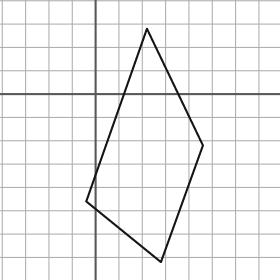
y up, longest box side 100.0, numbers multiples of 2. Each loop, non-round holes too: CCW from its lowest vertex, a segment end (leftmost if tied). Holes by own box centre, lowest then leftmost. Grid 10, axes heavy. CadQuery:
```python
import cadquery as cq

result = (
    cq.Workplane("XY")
    .moveTo(28.0, -72.0)
    .lineTo(46.0, -22.0)
    .lineTo(22.0, 28.0)
    .lineTo(-4.0, -46.0)
    .close()
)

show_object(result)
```